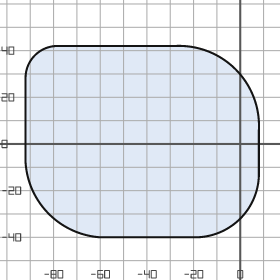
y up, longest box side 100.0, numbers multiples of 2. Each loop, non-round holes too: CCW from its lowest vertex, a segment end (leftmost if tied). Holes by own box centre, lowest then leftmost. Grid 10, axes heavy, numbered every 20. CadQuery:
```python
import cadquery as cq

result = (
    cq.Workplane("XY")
    .moveTo(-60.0, -40.0)
    .lineTo(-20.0, -40.0)
    .threePointArc((0.0, -32.0), (8.0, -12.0))
    .lineTo(8.0, 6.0)
    .threePointArc((-2.0, 32.0), (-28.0, 42.0))
    .lineTo(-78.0, 42.0)
    .threePointArc((-88.0, 38.0), (-92.0, 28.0))
    .lineTo(-92.0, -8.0)
    .threePointArc((-82.0, -30.0), (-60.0, -40.0))
    .close()
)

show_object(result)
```